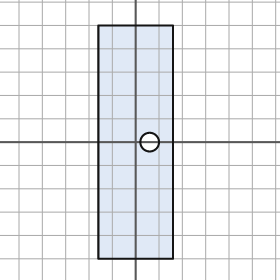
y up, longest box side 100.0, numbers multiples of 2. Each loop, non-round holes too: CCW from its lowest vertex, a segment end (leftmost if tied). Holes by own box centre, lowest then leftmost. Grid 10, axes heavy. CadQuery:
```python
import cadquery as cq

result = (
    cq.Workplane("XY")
    .moveTo(-16.0, -50.0)
    .lineTo(16.0, -50.0)
    .lineTo(16.0, 50.0)
    .lineTo(-16.0, 50.0)
    .close()
    .moveTo(6.0, 0.0)
    .circle(4.0)
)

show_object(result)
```